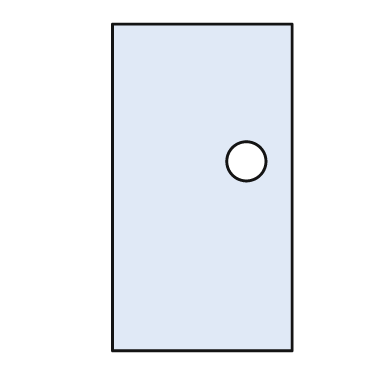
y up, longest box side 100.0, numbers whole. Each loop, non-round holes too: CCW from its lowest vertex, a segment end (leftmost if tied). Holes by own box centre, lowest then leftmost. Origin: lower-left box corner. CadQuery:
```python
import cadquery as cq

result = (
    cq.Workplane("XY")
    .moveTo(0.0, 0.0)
    .lineTo(55.0, 0.0)
    .lineTo(55.0, 100.0)
    .lineTo(0.0, 100.0)
    .close()
    .moveTo(41.0, 58.0)
    .circle(6.0)
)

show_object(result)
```